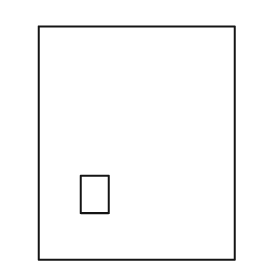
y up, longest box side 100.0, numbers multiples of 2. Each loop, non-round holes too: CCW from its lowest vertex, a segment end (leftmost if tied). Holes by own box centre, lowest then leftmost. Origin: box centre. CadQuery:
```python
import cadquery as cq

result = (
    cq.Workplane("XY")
    .moveTo(-42.0, -50.0)
    .lineTo(42.0, -50.0)
    .lineTo(42.0, 50.0)
    .lineTo(-42.0, 50.0)
    .close()
    .moveTo(-24.0, -30.0)
    .lineTo(-12.0, -30.0)
    .lineTo(-12.0, -14.0)
    .lineTo(-24.0, -14.0)
    .close()
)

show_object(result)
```